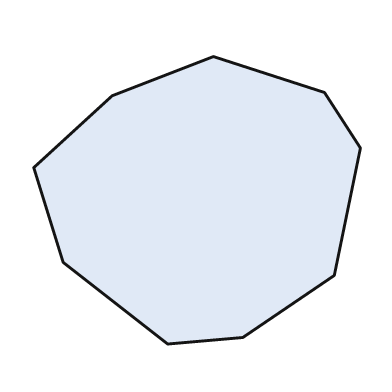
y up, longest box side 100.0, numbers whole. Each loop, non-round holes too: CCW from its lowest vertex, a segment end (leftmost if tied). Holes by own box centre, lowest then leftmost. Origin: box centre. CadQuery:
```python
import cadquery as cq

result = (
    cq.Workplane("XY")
    .moveTo(-9.0, -44.0)
    .lineTo(14.0, -42.0)
    .lineTo(42.0, -23.0)
    .lineTo(50.0, 16.0)
    .lineTo(39.0, 33.0)
    .lineTo(5.0, 44.0)
    .lineTo(-26.0, 32.0)
    .lineTo(-50.0, 10.0)
    .lineTo(-41.0, -19.0)
    .close()
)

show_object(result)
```